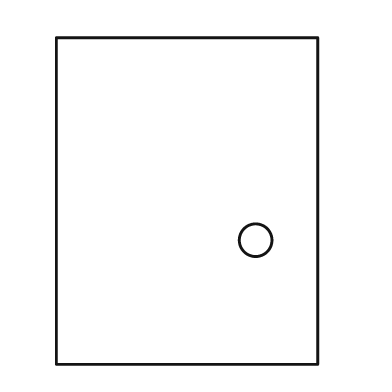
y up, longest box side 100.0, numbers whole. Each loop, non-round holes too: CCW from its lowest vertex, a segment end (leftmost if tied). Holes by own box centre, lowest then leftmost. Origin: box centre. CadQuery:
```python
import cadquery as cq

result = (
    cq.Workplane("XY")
    .moveTo(-40.0, -50.0)
    .lineTo(40.0, -50.0)
    .lineTo(40.0, 50.0)
    .lineTo(-40.0, 50.0)
    .close()
    .moveTo(21.0, -12.0)
    .circle(5.0)
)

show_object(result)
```